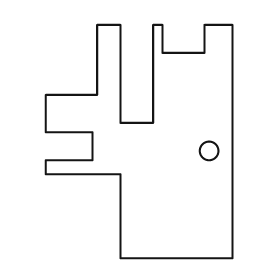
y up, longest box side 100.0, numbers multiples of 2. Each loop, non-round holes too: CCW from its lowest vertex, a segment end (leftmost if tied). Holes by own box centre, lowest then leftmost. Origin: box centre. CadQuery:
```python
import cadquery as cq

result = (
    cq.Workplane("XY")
    .moveTo(-8.0, -50.0)
    .lineTo(40.0, -50.0)
    .lineTo(40.0, 50.0)
    .lineTo(28.0, 50.0)
    .lineTo(28.0, 38.0)
    .lineTo(10.0, 38.0)
    .lineTo(10.0, 50.0)
    .lineTo(6.0, 50.0)
    .lineTo(6.0, 8.0)
    .lineTo(-8.0, 8.0)
    .lineTo(-8.0, 50.0)
    .lineTo(-18.0, 50.0)
    .lineTo(-18.0, 20.0)
    .lineTo(-40.0, 20.0)
    .lineTo(-40.0, 4.0)
    .lineTo(-20.0, 4.0)
    .lineTo(-20.0, -8.0)
    .lineTo(-40.0, -8.0)
    .lineTo(-40.0, -14.0)
    .lineTo(-8.0, -14.0)
    .close()
    .moveTo(30.0, -4.0)
    .circle(4.0)
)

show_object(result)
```